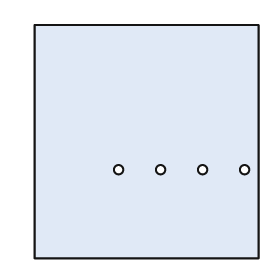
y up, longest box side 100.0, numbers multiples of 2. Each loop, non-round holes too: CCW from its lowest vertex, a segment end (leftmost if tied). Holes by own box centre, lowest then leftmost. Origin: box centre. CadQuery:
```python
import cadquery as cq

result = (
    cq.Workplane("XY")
    .moveTo(-48.0, -50.0)
    .lineTo(48.0, -50.0)
    .lineTo(48.0, 50.0)
    .lineTo(-48.0, 50.0)
    .close()
    .moveTo(-12.0, -12.0)
    .circle(2.0)
    .moveTo(6.0, -12.0)
    .circle(2.0)
    .moveTo(24.0, -12.0)
    .circle(2.0)
    .moveTo(42.0, -12.0)
    .circle(2.0)
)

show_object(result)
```